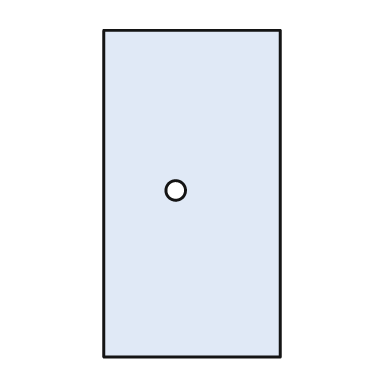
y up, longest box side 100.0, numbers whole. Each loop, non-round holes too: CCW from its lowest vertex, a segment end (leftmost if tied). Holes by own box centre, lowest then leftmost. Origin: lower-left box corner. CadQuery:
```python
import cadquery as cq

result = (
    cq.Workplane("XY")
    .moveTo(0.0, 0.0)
    .lineTo(54.0, 0.0)
    .lineTo(54.0, 100.0)
    .lineTo(0.0, 100.0)
    .close()
    .moveTo(22.0, 51.0)
    .circle(3.0)
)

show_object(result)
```